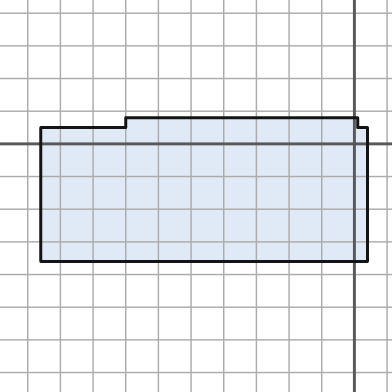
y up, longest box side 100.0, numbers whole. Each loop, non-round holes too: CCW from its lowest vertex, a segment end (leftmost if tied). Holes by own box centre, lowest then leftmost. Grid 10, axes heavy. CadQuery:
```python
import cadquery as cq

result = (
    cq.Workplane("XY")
    .moveTo(-96.0, -36.0)
    .lineTo(4.0, -36.0)
    .lineTo(4.0, 5.0)
    .lineTo(1.0, 5.0)
    .lineTo(1.0, 8.0)
    .lineTo(-70.0, 8.0)
    .lineTo(-70.0, 5.0)
    .lineTo(-96.0, 5.0)
    .close()
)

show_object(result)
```